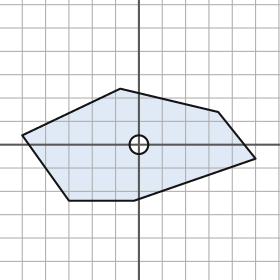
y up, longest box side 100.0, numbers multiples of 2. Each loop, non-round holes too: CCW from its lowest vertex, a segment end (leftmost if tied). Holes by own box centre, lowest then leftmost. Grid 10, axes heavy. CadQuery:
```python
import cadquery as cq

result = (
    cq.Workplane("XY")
    .moveTo(-30.0, -24.0)
    .lineTo(-2.0, -24.0)
    .lineTo(50.0, -6.0)
    .lineTo(34.0, 14.0)
    .lineTo(-8.0, 24.0)
    .lineTo(-50.0, 4.0)
    .close()
    .moveTo(0.0, 0.0)
    .circle(4.0)
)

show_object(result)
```